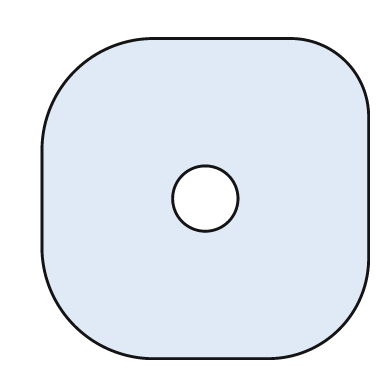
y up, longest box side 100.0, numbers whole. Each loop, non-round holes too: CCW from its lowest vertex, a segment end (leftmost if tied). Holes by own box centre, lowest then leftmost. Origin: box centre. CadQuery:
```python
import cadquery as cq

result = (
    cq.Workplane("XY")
    .moveTo(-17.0, -49.0)
    .lineTo(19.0, -49.0)
    .threePointArc((41.0, -40.0), (50.0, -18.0))
    .lineTo(50.0, 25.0)
    .threePointArc((43.0, 42.0), (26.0, 49.0))
    .lineTo(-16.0, 49.0)
    .threePointArc((-40.0, 39.0), (-50.0, 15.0))
    .lineTo(-50.0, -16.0)
    .threePointArc((-40.0, -39.0), (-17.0, -49.0))
    .close()
    .moveTo(0.0, 0.0)
    .circle(10.0)
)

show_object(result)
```